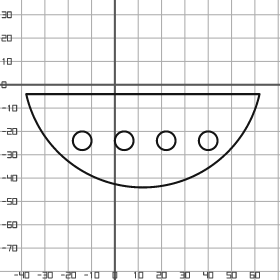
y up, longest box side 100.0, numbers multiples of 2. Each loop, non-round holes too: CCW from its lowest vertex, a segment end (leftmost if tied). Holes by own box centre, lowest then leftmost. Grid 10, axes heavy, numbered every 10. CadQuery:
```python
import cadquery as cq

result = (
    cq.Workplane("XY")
    .moveTo(-38.0, -4.0)
    .threePointArc((12.0, -44.0), (62.0, -4.0))
    .close()
    .moveTo(-14.0, -24.0)
    .circle(4.0)
    .moveTo(4.0, -24.0)
    .circle(4.0)
    .moveTo(22.0, -24.0)
    .circle(4.0)
    .moveTo(40.0, -24.0)
    .circle(4.0)
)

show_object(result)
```